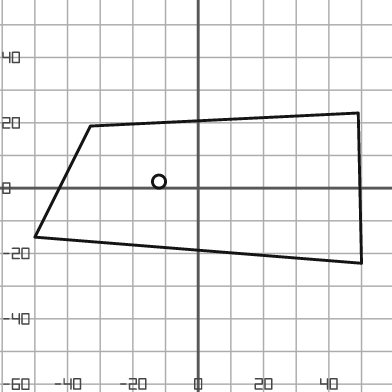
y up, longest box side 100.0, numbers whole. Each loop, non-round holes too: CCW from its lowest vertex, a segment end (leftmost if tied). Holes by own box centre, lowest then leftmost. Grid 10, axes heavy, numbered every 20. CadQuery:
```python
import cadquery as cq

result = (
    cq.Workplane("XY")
    .moveTo(50.0, -23.0)
    .lineTo(49.0, 23.0)
    .lineTo(-33.0, 19.0)
    .lineTo(-50.0, -15.0)
    .close()
    .moveTo(-12.0, 2.0)
    .circle(2.0)
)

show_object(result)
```